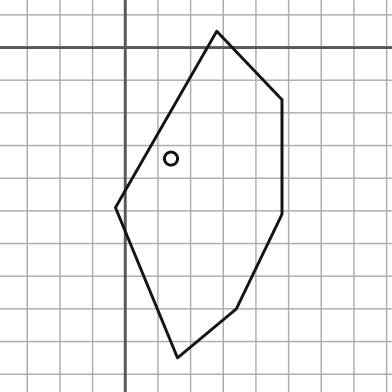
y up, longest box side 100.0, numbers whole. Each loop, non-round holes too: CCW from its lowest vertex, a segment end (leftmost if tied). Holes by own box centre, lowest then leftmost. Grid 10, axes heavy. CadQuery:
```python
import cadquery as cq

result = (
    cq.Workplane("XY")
    .moveTo(16.0, -95.0)
    .lineTo(34.0, -80.0)
    .lineTo(48.0, -51.0)
    .lineTo(48.0, -16.0)
    .lineTo(28.0, 5.0)
    .lineTo(-3.0, -49.0)
    .close()
    .moveTo(14.0, -34.0)
    .circle(2.0)
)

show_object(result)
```